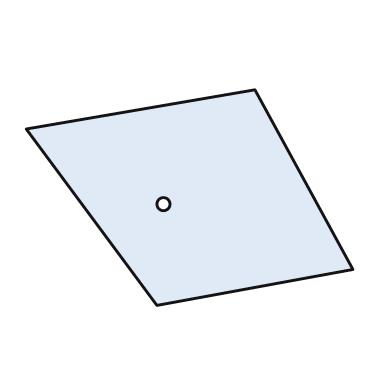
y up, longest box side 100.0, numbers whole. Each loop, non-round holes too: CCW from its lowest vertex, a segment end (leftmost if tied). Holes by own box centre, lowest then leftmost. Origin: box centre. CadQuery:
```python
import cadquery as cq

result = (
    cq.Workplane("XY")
    .moveTo(-10.0, -33.0)
    .lineTo(50.0, -22.0)
    .lineTo(20.0, 33.0)
    .lineTo(-50.0, 21.0)
    .close()
    .moveTo(-8.0, -2.0)
    .circle(2.0)
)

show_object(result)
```